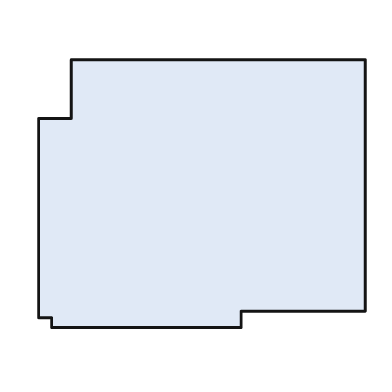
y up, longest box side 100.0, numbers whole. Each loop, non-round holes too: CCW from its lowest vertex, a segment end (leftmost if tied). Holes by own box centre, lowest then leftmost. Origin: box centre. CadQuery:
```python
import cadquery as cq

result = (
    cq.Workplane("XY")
    .moveTo(-46.0, -41.0)
    .lineTo(12.0, -41.0)
    .lineTo(12.0, -36.0)
    .lineTo(50.0, -36.0)
    .lineTo(50.0, 41.0)
    .lineTo(-40.0, 41.0)
    .lineTo(-40.0, 23.0)
    .lineTo(-50.0, 23.0)
    .lineTo(-50.0, -38.0)
    .lineTo(-46.0, -38.0)
    .close()
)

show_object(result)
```